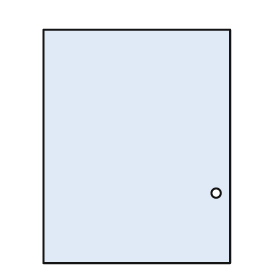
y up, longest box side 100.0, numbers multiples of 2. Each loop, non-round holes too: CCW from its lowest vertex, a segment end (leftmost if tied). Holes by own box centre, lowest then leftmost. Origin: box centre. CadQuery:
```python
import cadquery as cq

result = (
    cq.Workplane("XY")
    .moveTo(-40.0, -50.0)
    .lineTo(40.0, -50.0)
    .lineTo(40.0, 50.0)
    .lineTo(-40.0, 50.0)
    .close()
    .moveTo(34.0, -20.0)
    .circle(2.0)
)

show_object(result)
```